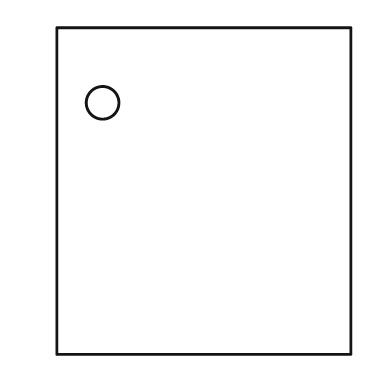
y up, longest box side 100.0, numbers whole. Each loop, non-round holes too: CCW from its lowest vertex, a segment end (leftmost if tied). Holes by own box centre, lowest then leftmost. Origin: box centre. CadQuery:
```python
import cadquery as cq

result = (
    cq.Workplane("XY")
    .moveTo(-45.0, -50.0)
    .lineTo(45.0, -50.0)
    .lineTo(45.0, 50.0)
    .lineTo(-45.0, 50.0)
    .close()
    .moveTo(-31.0, 27.0)
    .circle(5.0)
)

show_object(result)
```